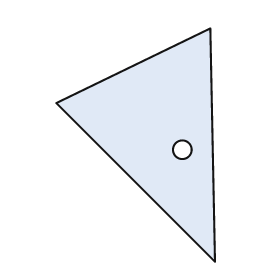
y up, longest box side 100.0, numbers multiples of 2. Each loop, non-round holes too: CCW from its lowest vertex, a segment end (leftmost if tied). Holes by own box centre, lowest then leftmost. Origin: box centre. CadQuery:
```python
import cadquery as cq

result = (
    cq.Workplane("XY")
    .moveTo(34.0, -50.0)
    .lineTo(32.0, 50.0)
    .lineTo(-34.0, 18.0)
    .close()
    .moveTo(20.0, -2.0)
    .circle(4.0)
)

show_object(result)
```